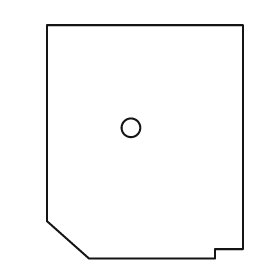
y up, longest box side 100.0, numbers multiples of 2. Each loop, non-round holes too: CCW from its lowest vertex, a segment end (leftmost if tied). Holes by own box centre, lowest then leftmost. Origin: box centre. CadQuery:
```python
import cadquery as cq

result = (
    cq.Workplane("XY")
    .moveTo(-24.0, -50.0)
    .lineTo(30.0, -50.0)
    .lineTo(30.0, -46.0)
    .lineTo(42.0, -46.0)
    .lineTo(42.0, 50.0)
    .lineTo(-42.0, 50.0)
    .lineTo(-42.0, -34.0)
    .close()
    .moveTo(-6.0, 6.0)
    .circle(4.0)
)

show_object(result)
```